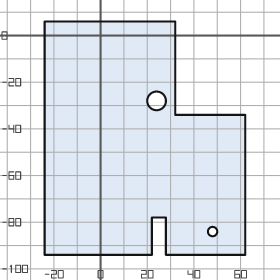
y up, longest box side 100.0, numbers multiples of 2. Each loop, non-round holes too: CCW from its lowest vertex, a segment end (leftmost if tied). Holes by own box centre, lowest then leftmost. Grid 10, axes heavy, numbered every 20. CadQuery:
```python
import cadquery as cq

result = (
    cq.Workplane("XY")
    .moveTo(-24.0, -94.0)
    .lineTo(22.0, -94.0)
    .lineTo(22.0, -78.0)
    .lineTo(28.0, -78.0)
    .lineTo(28.0, -94.0)
    .lineTo(62.0, -94.0)
    .lineTo(62.0, -34.0)
    .lineTo(32.0, -34.0)
    .lineTo(32.0, 6.0)
    .lineTo(-24.0, 6.0)
    .close()
    .moveTo(48.0, -84.0)
    .circle(2.0)
    .moveTo(24.0, -28.0)
    .circle(4.0)
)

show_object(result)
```